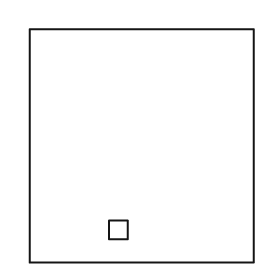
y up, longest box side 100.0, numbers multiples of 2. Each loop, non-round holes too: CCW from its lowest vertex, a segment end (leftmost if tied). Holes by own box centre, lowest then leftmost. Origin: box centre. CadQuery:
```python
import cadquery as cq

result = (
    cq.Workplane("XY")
    .moveTo(-48.0, -50.0)
    .lineTo(48.0, -50.0)
    .lineTo(48.0, 50.0)
    .lineTo(-48.0, 50.0)
    .close()
    .moveTo(-14.0, -40.0)
    .lineTo(-6.0, -40.0)
    .lineTo(-6.0, -32.0)
    .lineTo(-14.0, -32.0)
    .close()
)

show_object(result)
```